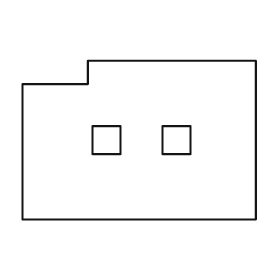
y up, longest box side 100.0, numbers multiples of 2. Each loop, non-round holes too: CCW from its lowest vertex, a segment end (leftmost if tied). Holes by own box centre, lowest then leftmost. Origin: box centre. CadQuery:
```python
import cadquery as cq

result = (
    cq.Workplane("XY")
    .moveTo(-50.0, -34.0)
    .lineTo(50.0, -34.0)
    .lineTo(50.0, 34.0)
    .lineTo(-22.0, 34.0)
    .lineTo(-22.0, 24.0)
    .lineTo(-50.0, 24.0)
    .close()
    .moveTo(-20.0, -6.0)
    .lineTo(-8.0, -6.0)
    .lineTo(-8.0, 6.0)
    .lineTo(-20.0, 6.0)
    .close()
    .moveTo(10.0, -6.0)
    .lineTo(22.0, -6.0)
    .lineTo(22.0, 6.0)
    .lineTo(10.0, 6.0)
    .close()
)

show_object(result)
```